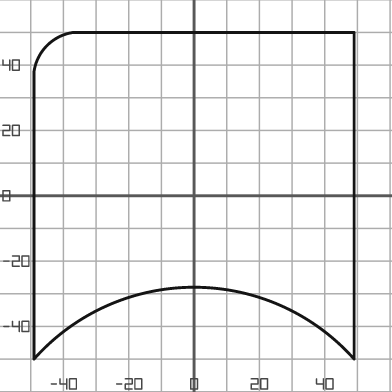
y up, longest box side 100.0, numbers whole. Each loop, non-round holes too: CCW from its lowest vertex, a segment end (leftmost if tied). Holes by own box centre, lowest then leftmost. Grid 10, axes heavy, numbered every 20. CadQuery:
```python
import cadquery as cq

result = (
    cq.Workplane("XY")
    .moveTo(-49.0, -50.0)
    .threePointArc((0.0, -28.0), (49.0, -50.0))
    .lineTo(49.0, 50.0)
    .lineTo(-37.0, 50.0)
    .threePointArc((-45.0, 46.0), (-49.0, 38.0))
    .close()
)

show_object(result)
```